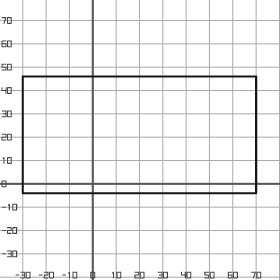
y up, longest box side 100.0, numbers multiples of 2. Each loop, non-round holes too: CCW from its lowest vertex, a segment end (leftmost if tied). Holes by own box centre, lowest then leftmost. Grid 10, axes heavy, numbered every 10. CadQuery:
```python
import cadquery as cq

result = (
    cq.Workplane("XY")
    .moveTo(-30.0, -4.0)
    .lineTo(70.0, -4.0)
    .lineTo(70.0, 46.0)
    .lineTo(-30.0, 46.0)
    .close()
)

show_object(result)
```